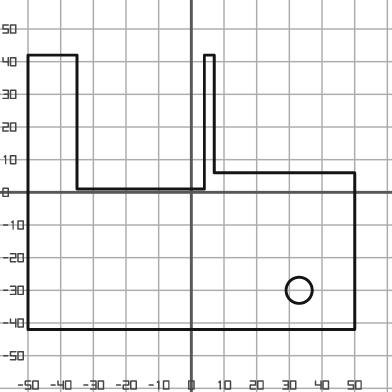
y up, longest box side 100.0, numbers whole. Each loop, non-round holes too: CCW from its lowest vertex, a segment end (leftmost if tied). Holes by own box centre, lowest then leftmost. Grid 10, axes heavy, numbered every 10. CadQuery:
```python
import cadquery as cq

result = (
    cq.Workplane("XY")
    .moveTo(-50.0, -42.0)
    .lineTo(50.0, -42.0)
    .lineTo(50.0, 6.0)
    .lineTo(7.0, 6.0)
    .lineTo(7.0, 42.0)
    .lineTo(4.0, 42.0)
    .lineTo(4.0, 1.0)
    .lineTo(-35.0, 1.0)
    .lineTo(-35.0, 42.0)
    .lineTo(-50.0, 42.0)
    .close()
    .moveTo(33.0, -30.0)
    .circle(4.0)
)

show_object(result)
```